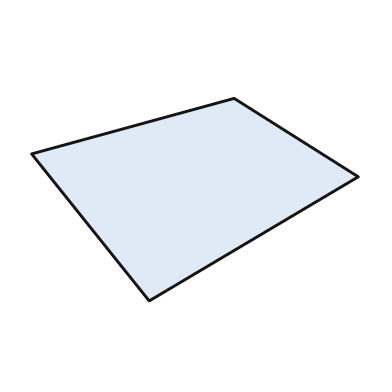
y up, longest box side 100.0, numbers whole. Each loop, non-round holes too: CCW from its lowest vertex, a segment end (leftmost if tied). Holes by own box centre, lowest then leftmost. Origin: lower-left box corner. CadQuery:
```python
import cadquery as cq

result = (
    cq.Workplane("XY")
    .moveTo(36.0, 0.0)
    .lineTo(100.0, 38.0)
    .lineTo(62.0, 62.0)
    .lineTo(0.0, 45.0)
    .close()
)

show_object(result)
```